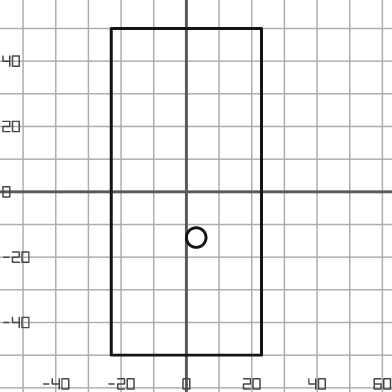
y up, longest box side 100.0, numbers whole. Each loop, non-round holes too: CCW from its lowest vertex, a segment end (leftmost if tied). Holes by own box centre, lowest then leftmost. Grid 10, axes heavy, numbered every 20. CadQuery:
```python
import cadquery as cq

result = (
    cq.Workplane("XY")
    .moveTo(-23.0, -50.0)
    .lineTo(23.0, -50.0)
    .lineTo(23.0, 50.0)
    .lineTo(-23.0, 50.0)
    .close()
    .moveTo(3.0, -14.0)
    .circle(3.0)
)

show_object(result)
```